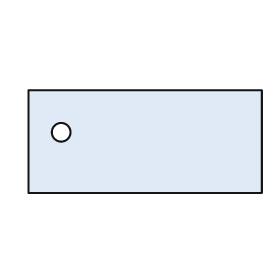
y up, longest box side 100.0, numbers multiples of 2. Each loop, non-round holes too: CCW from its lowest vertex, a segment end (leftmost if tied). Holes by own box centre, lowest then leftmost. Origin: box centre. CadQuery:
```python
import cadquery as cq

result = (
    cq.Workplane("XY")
    .moveTo(-50.0, -22.0)
    .lineTo(50.0, -22.0)
    .lineTo(50.0, 22.0)
    .lineTo(-50.0, 22.0)
    .close()
    .moveTo(-36.0, 4.0)
    .circle(4.0)
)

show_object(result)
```